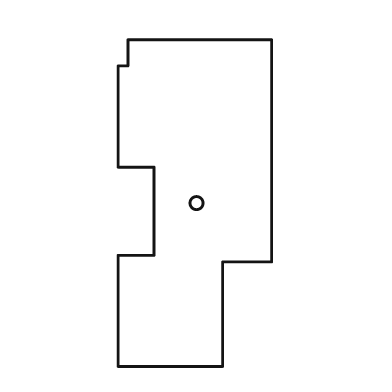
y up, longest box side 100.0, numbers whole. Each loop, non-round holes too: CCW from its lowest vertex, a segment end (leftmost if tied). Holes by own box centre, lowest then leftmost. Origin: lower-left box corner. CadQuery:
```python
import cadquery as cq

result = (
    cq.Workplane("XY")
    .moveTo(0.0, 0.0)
    .lineTo(32.0, 0.0)
    .lineTo(32.0, 32.0)
    .lineTo(47.0, 32.0)
    .lineTo(47.0, 100.0)
    .lineTo(3.0, 100.0)
    .lineTo(3.0, 92.0)
    .lineTo(0.0, 92.0)
    .lineTo(0.0, 61.0)
    .lineTo(11.0, 61.0)
    .lineTo(11.0, 34.0)
    .lineTo(0.0, 34.0)
    .close()
    .moveTo(24.0, 50.0)
    .circle(2.0)
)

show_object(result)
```